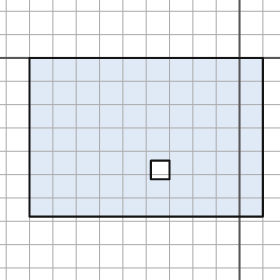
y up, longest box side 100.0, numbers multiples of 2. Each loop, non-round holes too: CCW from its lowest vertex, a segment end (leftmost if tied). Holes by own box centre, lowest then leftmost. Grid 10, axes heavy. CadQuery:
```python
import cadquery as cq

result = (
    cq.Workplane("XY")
    .moveTo(-90.0, -68.0)
    .lineTo(10.0, -68.0)
    .lineTo(10.0, 0.0)
    .lineTo(-90.0, 0.0)
    .close()
    .moveTo(-38.0, -52.0)
    .lineTo(-30.0, -52.0)
    .lineTo(-30.0, -44.0)
    .lineTo(-38.0, -44.0)
    .close()
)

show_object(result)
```